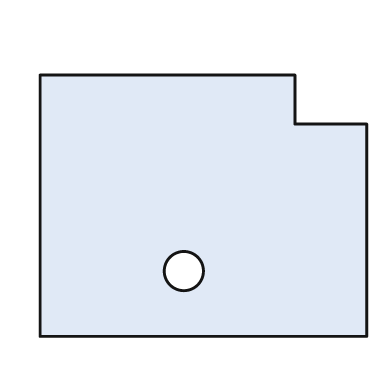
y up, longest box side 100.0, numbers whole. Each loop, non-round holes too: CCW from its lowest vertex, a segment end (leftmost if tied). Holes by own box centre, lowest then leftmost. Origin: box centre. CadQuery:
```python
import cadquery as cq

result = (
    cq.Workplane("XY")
    .moveTo(-50.0, -40.0)
    .lineTo(50.0, -40.0)
    .lineTo(50.0, 25.0)
    .lineTo(28.0, 25.0)
    .lineTo(28.0, 40.0)
    .lineTo(-50.0, 40.0)
    .close()
    .moveTo(-6.0, -20.0)
    .circle(6.0)
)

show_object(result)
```